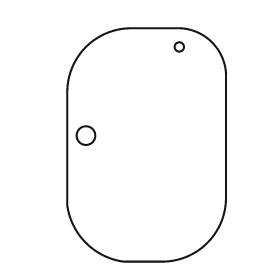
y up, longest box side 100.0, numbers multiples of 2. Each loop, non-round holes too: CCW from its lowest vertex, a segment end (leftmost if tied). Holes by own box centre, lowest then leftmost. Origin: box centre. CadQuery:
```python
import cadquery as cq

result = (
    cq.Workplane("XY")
    .moveTo(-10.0, -50.0)
    .lineTo(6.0, -50.0)
    .threePointArc((26.0, -42.0), (34.0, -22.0))
    .lineTo(34.0, 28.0)
    .threePointArc((28.0, 44.0), (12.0, 50.0))
    .lineTo(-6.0, 50.0)
    .threePointArc((-26.0, 42.0), (-34.0, 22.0))
    .lineTo(-34.0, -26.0)
    .threePointArc((-26.0, -42.0), (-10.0, -50.0))
    .close()
    .moveTo(-26.0, 4.0)
    .circle(4.0)
    .moveTo(14.0, 42.0)
    .circle(2.0)
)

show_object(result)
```